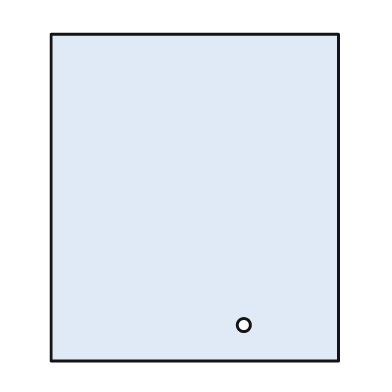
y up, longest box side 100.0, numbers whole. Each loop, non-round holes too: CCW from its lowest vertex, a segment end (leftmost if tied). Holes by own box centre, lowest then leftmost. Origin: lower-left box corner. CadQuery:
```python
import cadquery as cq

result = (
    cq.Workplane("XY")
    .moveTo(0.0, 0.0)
    .lineTo(88.0, 0.0)
    .lineTo(88.0, 100.0)
    .lineTo(0.0, 100.0)
    .close()
    .moveTo(59.0, 11.0)
    .circle(2.0)
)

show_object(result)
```